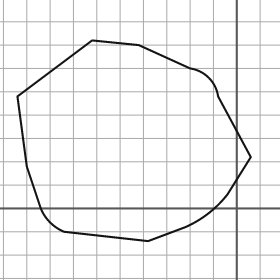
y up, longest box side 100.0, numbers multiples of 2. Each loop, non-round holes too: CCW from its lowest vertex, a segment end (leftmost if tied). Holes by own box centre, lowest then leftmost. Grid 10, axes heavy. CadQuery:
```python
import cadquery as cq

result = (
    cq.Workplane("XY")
    .moveTo(-38.0, -14.0)
    .lineTo(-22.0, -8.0)
    .threePointArc((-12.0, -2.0), (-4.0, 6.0))
    .lineTo(6.0, 22.0)
    .lineTo(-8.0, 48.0)
    .threePointArc((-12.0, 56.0), (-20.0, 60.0))
    .lineTo(-42.0, 70.0)
    .lineTo(-62.0, 72.0)
    .lineTo(-94.0, 48.0)
    .lineTo(-90.0, 18.0)
    .lineTo(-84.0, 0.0)
    .threePointArc((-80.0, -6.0), (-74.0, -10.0))
    .close()
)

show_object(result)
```